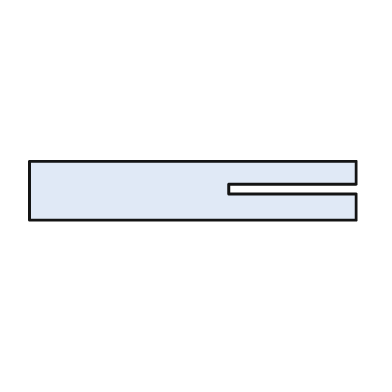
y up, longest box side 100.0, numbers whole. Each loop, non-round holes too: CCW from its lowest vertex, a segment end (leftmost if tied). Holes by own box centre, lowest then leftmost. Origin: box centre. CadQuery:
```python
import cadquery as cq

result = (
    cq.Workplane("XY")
    .moveTo(-50.0, -9.0)
    .lineTo(50.0, -9.0)
    .lineTo(50.0, -1.0)
    .lineTo(11.0, -1.0)
    .lineTo(11.0, 2.0)
    .lineTo(50.0, 2.0)
    .lineTo(50.0, 9.0)
    .lineTo(-50.0, 9.0)
    .close()
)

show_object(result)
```